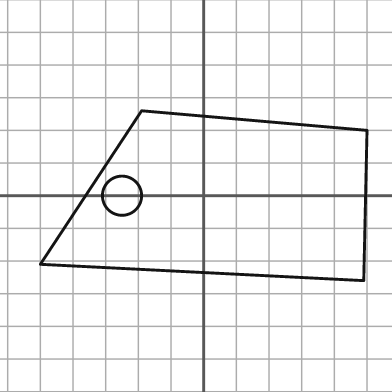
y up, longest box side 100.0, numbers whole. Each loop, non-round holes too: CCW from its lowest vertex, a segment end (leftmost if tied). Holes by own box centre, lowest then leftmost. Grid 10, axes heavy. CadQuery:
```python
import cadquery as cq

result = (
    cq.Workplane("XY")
    .moveTo(49.0, -26.0)
    .lineTo(50.0, 20.0)
    .lineTo(-19.0, 26.0)
    .lineTo(-50.0, -21.0)
    .close()
    .moveTo(-25.0, 0.0)
    .circle(6.0)
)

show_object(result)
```